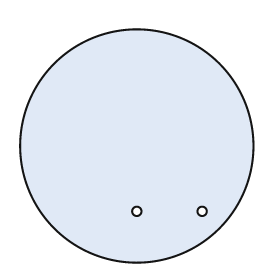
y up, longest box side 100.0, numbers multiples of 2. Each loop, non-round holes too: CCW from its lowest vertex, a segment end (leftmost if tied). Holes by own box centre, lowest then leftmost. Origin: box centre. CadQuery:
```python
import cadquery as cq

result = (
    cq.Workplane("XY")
    .moveTo(0.0, 0.0)
    .circle(50.0)
    .moveTo(0.0, -28.0)
    .circle(2.0)
    .moveTo(28.0, -28.0)
    .circle(2.0)
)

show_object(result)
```